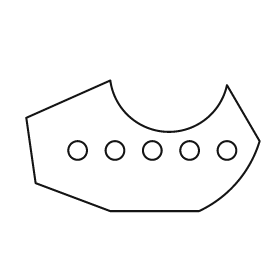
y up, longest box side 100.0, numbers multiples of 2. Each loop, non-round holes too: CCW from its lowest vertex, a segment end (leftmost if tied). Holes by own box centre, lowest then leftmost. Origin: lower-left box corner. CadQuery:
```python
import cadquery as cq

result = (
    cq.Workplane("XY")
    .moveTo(36.0, 0.0)
    .lineTo(74.0, 0.0)
    .threePointArc((90.0, 12.0), (100.0, 30.0))
    .lineTo(86.0, 54.0)
    .threePointArc((60.0, 34.0), (36.0, 56.0))
    .lineTo(0.0, 40.0)
    .lineTo(4.0, 12.0)
    .close()
    .moveTo(22.0, 26.0)
    .circle(4.0)
    .moveTo(38.0, 26.0)
    .circle(4.0)
    .moveTo(54.0, 26.0)
    .circle(4.0)
    .moveTo(70.0, 26.0)
    .circle(4.0)
    .moveTo(86.0, 26.0)
    .circle(4.0)
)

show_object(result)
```